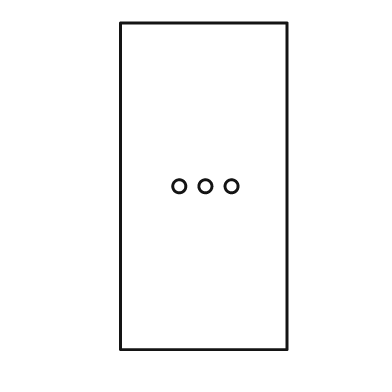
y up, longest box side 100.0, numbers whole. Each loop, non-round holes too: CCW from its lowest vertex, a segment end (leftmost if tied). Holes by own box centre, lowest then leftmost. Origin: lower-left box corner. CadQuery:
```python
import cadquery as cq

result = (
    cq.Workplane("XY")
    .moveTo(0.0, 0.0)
    .lineTo(51.0, 0.0)
    .lineTo(51.0, 100.0)
    .lineTo(0.0, 100.0)
    .close()
    .moveTo(18.0, 50.0)
    .circle(2.0)
    .moveTo(26.0, 50.0)
    .circle(2.0)
    .moveTo(34.0, 50.0)
    .circle(2.0)
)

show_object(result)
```